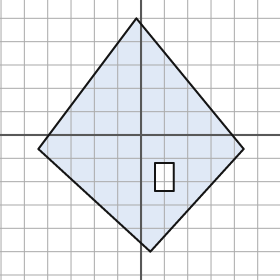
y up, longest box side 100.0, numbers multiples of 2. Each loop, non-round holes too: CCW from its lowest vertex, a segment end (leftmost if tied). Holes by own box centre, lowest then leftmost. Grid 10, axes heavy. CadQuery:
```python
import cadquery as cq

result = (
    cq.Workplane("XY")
    .moveTo(4.0, -50.0)
    .lineTo(44.0, -6.0)
    .lineTo(-2.0, 50.0)
    .lineTo(-44.0, -6.0)
    .close()
    .moveTo(6.0, -24.0)
    .lineTo(14.0, -24.0)
    .lineTo(14.0, -12.0)
    .lineTo(6.0, -12.0)
    .close()
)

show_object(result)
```